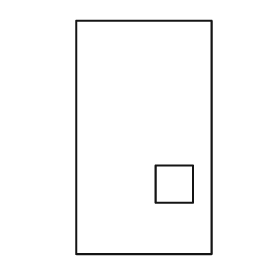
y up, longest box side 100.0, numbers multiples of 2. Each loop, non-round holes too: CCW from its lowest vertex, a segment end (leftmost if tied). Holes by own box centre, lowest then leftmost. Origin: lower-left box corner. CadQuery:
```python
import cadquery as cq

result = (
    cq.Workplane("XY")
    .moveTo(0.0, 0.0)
    .lineTo(58.0, 0.0)
    .lineTo(58.0, 100.0)
    .lineTo(0.0, 100.0)
    .close()
    .moveTo(34.0, 22.0)
    .lineTo(50.0, 22.0)
    .lineTo(50.0, 38.0)
    .lineTo(34.0, 38.0)
    .close()
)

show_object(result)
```